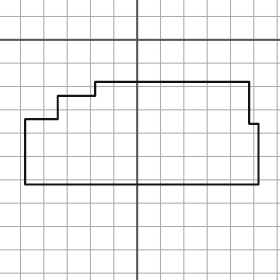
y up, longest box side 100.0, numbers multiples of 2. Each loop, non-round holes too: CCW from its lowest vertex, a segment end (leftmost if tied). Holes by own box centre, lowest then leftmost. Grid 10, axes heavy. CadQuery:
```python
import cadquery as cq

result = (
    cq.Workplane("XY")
    .moveTo(-48.0, -62.0)
    .lineTo(52.0, -62.0)
    .lineTo(52.0, -36.0)
    .lineTo(48.0, -36.0)
    .lineTo(48.0, -18.0)
    .lineTo(-18.0, -18.0)
    .lineTo(-18.0, -24.0)
    .lineTo(-34.0, -24.0)
    .lineTo(-34.0, -34.0)
    .lineTo(-48.0, -34.0)
    .close()
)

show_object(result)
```